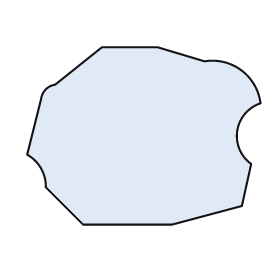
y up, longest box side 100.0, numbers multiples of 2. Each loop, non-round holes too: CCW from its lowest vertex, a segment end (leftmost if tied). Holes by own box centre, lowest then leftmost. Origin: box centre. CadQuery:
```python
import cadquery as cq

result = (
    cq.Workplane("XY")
    .moveTo(-26.0, -38.0)
    .lineTo(12.0, -38.0)
    .lineTo(42.0, -30.0)
    .lineTo(46.0, -12.0)
    .threePointArc((40.0, 2.0), (50.0, 14.0))
    .threePointArc((42.0, 28.0), (26.0, 32.0))
    .lineTo(6.0, 38.0)
    .lineTo(-18.0, 38.0)
    .lineTo(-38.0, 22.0)
    .threePointArc((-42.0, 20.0), (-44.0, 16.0))
    .lineTo(-50.0, -8.0)
    .threePointArc((-44.0, -14.0), (-42.0, -22.0))
    .close()
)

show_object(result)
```